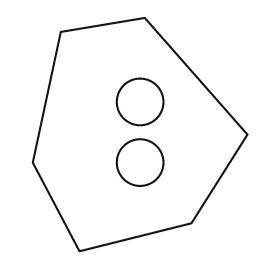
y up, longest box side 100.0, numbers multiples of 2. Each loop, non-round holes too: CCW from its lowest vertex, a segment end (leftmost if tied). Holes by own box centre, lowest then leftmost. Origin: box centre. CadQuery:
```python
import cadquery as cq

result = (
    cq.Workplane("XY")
    .moveTo(-26.0, -50.0)
    .lineTo(22.0, -38.0)
    .lineTo(46.0, 0.0)
    .lineTo(2.0, 50.0)
    .lineTo(-34.0, 44.0)
    .lineTo(-46.0, -12.0)
    .close()
    .moveTo(0.0, -12.0)
    .circle(10.0)
    .moveTo(0.0, 14.0)
    .circle(10.0)
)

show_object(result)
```